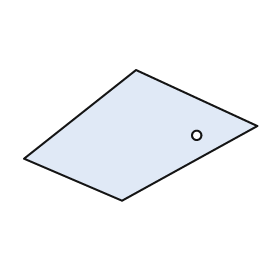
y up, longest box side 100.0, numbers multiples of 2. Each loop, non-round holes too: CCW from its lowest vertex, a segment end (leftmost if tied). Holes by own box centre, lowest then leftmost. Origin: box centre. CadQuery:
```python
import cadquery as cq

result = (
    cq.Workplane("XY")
    .moveTo(-8.0, -28.0)
    .lineTo(50.0, 4.0)
    .lineTo(-2.0, 28.0)
    .lineTo(-50.0, -10.0)
    .close()
    .moveTo(24.0, 0.0)
    .circle(2.0)
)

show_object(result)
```